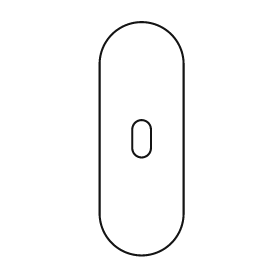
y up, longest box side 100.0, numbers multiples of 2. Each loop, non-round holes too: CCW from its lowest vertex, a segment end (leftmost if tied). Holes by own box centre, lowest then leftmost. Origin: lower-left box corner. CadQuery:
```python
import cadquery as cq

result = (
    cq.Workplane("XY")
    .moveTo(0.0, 18.0)
    .threePointArc((18.0, 0.0), (36.0, 18.0))
    .lineTo(36.0, 82.0)
    .threePointArc((18.0, 100.0), (0.0, 82.0))
    .close()
    .moveTo(14.0, 46.0)
    .threePointArc((18.0, 42.0), (22.0, 46.0))
    .lineTo(22.0, 54.0)
    .threePointArc((18.0, 58.0), (14.0, 54.0))
    .close()
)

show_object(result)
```